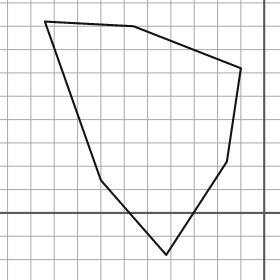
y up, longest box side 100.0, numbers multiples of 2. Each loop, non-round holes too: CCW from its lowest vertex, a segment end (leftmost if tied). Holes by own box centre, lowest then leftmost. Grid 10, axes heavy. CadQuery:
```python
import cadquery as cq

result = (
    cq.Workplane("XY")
    .moveTo(-42.0, -18.0)
    .lineTo(-16.0, 22.0)
    .lineTo(-10.0, 62.0)
    .lineTo(-56.0, 80.0)
    .lineTo(-94.0, 82.0)
    .lineTo(-70.0, 14.0)
    .close()
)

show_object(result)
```